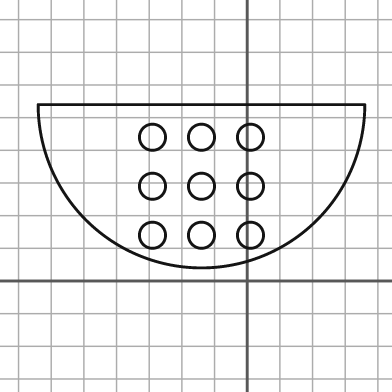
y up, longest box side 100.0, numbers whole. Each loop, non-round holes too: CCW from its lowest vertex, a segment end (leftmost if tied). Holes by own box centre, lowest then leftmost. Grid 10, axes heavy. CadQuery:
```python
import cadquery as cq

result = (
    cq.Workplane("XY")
    .moveTo(-64.0, 54.0)
    .threePointArc((-14.0, 4.0), (36.0, 54.0))
    .close()
    .moveTo(-29.0, 14.0)
    .circle(4.0)
    .moveTo(-14.0, 14.0)
    .circle(4.0)
    .moveTo(1.0, 14.0)
    .circle(4.0)
    .moveTo(-29.0, 29.0)
    .circle(4.0)
    .moveTo(-14.0, 29.0)
    .circle(4.0)
    .moveTo(1.0, 29.0)
    .circle(4.0)
    .moveTo(-29.0, 44.0)
    .circle(4.0)
    .moveTo(-14.0, 44.0)
    .circle(4.0)
    .moveTo(1.0, 44.0)
    .circle(4.0)
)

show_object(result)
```